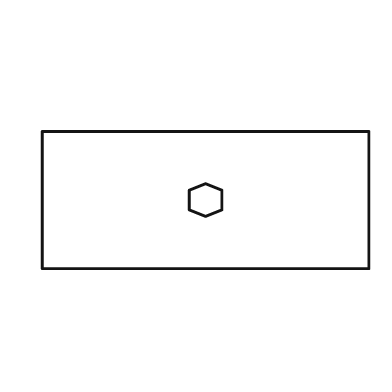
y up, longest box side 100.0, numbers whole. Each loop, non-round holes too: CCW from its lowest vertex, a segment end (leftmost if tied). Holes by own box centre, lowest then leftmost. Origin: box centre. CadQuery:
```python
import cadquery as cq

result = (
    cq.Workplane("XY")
    .moveTo(-50.0, -21.0)
    .lineTo(50.0, -21.0)
    .lineTo(50.0, 21.0)
    .lineTo(-50.0, 21.0)
    .close()
    .moveTo(0.0, -5.0)
    .lineTo(5.0, -3.0)
    .lineTo(5.0, 3.0)
    .lineTo(0.0, 5.0)
    .lineTo(-5.0, 3.0)
    .lineTo(-5.0, -3.0)
    .close()
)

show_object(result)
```